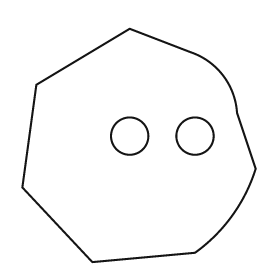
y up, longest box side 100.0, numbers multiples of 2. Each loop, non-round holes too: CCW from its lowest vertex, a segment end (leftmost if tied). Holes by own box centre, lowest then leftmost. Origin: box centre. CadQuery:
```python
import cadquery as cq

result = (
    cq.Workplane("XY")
    .moveTo(-20.0, -50.0)
    .lineTo(24.0, -46.0)
    .threePointArc((40.0, -30.0), (50.0, -10.0))
    .lineTo(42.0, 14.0)
    .threePointArc((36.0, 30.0), (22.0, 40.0))
    .lineTo(-4.0, 50.0)
    .lineTo(-44.0, 26.0)
    .lineTo(-50.0, -18.0)
    .close()
    .moveTo(-4.0, 4.0)
    .circle(8.0)
    .moveTo(24.0, 4.0)
    .circle(8.0)
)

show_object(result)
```